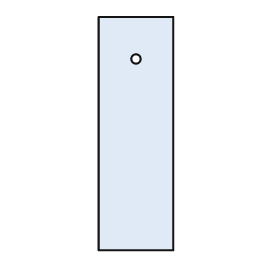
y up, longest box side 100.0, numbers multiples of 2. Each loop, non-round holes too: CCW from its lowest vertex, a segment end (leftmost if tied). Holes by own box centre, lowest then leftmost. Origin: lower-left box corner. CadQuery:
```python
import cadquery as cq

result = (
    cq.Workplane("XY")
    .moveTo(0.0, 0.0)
    .lineTo(32.0, 0.0)
    .lineTo(32.0, 100.0)
    .lineTo(0.0, 100.0)
    .close()
    .moveTo(16.0, 82.0)
    .circle(2.0)
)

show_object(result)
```